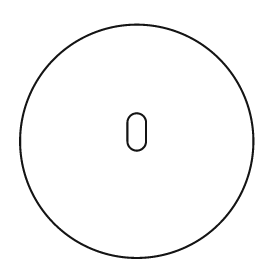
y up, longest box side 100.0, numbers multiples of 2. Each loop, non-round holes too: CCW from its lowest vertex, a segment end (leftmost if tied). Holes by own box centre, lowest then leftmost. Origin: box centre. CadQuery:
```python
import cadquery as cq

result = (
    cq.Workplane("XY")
    .moveTo(0.0, 0.0)
    .circle(50.0)
    .moveTo(-4.0, 0.0)
    .threePointArc((0.0, -4.0), (4.0, 0.0))
    .lineTo(4.0, 8.0)
    .threePointArc((0.0, 12.0), (-4.0, 8.0))
    .close()
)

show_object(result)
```